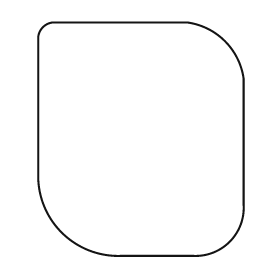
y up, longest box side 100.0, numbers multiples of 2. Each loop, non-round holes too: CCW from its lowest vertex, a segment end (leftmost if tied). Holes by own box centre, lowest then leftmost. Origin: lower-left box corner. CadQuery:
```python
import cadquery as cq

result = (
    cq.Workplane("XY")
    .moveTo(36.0, 0.0)
    .lineTo(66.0, 0.0)
    .threePointArc((82.0, 6.0), (88.0, 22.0))
    .lineTo(88.0, 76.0)
    .threePointArc((80.0, 92.0), (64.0, 100.0))
    .lineTo(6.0, 100.0)
    .threePointArc((2.0, 98.0), (0.0, 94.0))
    .lineTo(0.0, 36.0)
    .threePointArc((10.0, 10.0), (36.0, 0.0))
    .close()
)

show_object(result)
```